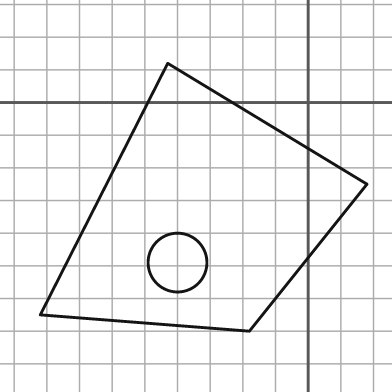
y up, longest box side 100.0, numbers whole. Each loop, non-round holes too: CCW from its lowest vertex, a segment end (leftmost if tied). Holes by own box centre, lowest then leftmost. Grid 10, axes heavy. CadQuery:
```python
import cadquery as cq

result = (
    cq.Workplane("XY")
    .moveTo(-18.0, -70.0)
    .lineTo(18.0, -25.0)
    .lineTo(-43.0, 12.0)
    .lineTo(-82.0, -65.0)
    .close()
    .moveTo(-40.0, -49.0)
    .circle(9.0)
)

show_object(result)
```